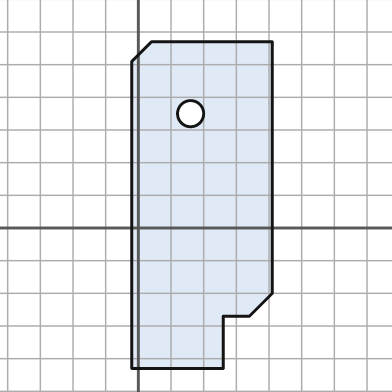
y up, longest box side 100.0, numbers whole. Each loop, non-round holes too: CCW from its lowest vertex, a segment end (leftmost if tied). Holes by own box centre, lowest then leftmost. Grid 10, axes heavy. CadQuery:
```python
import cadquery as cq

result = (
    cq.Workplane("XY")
    .moveTo(-2.0, -43.0)
    .lineTo(26.0, -43.0)
    .lineTo(26.0, -27.0)
    .lineTo(34.0, -27.0)
    .lineTo(41.0, -20.0)
    .lineTo(41.0, 57.0)
    .lineTo(4.0, 57.0)
    .lineTo(-2.0, 51.0)
    .close()
    .moveTo(16.0, 35.0)
    .circle(4.0)
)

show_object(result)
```